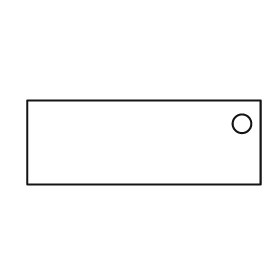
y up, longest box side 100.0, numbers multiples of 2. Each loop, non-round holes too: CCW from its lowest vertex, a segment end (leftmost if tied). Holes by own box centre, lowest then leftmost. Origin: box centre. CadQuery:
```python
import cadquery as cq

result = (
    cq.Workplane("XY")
    .moveTo(-50.0, -18.0)
    .lineTo(50.0, -18.0)
    .lineTo(50.0, 18.0)
    .lineTo(-50.0, 18.0)
    .close()
    .moveTo(42.0, 8.0)
    .circle(4.0)
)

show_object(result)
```